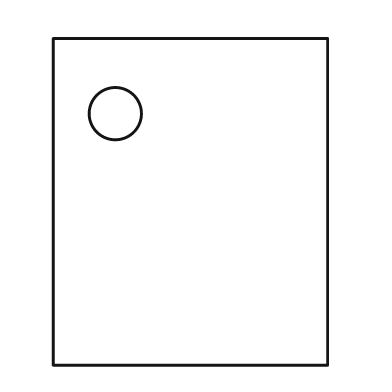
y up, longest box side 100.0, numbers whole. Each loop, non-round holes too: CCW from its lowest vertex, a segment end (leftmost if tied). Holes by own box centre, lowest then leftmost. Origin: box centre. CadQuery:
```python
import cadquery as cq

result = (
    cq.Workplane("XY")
    .moveTo(-42.0, -50.0)
    .lineTo(42.0, -50.0)
    .lineTo(42.0, 50.0)
    .lineTo(-42.0, 50.0)
    .close()
    .moveTo(-23.0, 27.0)
    .circle(8.0)
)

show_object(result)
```